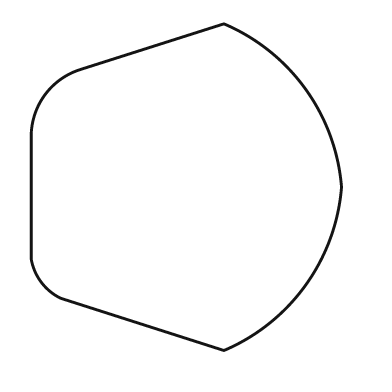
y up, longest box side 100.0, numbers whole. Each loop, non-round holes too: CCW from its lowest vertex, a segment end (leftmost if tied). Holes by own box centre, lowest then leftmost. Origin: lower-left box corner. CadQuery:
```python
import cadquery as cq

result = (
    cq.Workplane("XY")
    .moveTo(59.0, 0.0)
    .threePointArc((84.0, 20.0), (95.0, 50.0))
    .threePointArc((84.0, 80.0), (59.0, 100.0))
    .lineTo(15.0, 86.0)
    .threePointArc((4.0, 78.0), (0.0, 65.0))
    .lineTo(0.0, 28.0)
    .threePointArc((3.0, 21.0), (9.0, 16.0))
    .close()
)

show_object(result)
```